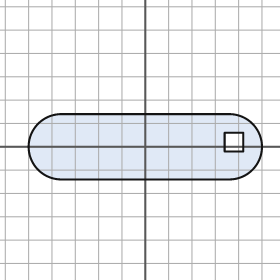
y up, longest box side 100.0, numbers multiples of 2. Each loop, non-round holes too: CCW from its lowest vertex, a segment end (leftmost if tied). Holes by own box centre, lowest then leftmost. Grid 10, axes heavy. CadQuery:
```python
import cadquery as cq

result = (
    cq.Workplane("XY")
    .moveTo(-36.0, -14.0)
    .lineTo(36.0, -14.0)
    .threePointArc((50.0, 0.0), (36.0, 14.0))
    .lineTo(-36.0, 14.0)
    .threePointArc((-50.0, 0.0), (-36.0, -14.0))
    .close()
    .moveTo(34.0, -2.0)
    .lineTo(42.0, -2.0)
    .lineTo(42.0, 6.0)
    .lineTo(34.0, 6.0)
    .close()
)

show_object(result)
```